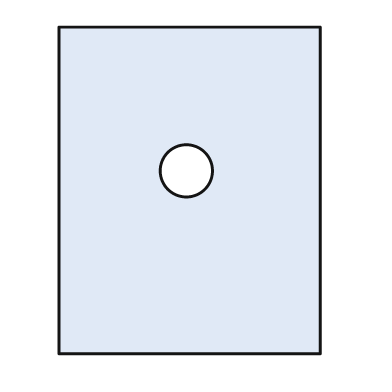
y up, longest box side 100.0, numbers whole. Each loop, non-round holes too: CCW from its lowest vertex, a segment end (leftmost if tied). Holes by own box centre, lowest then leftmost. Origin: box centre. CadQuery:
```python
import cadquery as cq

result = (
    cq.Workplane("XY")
    .moveTo(-40.0, -50.0)
    .lineTo(40.0, -50.0)
    .lineTo(40.0, 50.0)
    .lineTo(-40.0, 50.0)
    .close()
    .moveTo(-1.0, 6.0)
    .circle(8.0)
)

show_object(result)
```